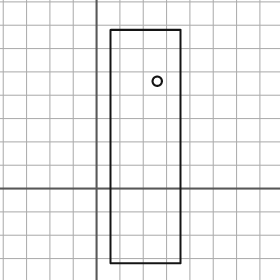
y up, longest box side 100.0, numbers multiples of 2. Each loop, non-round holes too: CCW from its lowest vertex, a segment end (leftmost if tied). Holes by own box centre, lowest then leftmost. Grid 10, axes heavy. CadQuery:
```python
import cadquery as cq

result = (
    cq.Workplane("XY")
    .moveTo(6.0, -32.0)
    .lineTo(36.0, -32.0)
    .lineTo(36.0, 68.0)
    .lineTo(6.0, 68.0)
    .close()
    .moveTo(26.0, 46.0)
    .circle(2.0)
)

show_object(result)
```